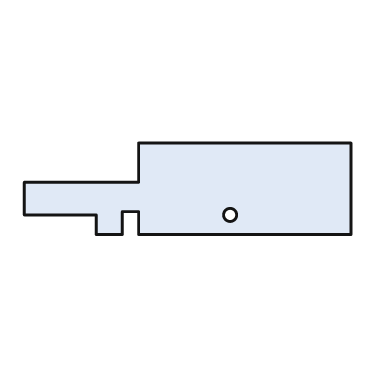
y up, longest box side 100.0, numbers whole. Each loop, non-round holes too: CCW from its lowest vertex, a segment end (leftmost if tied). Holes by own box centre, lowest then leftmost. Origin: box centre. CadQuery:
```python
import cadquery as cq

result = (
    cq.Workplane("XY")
    .moveTo(-28.0, -14.0)
    .lineTo(-20.0, -14.0)
    .lineTo(-20.0, -7.0)
    .lineTo(-15.0, -7.0)
    .lineTo(-15.0, -14.0)
    .lineTo(50.0, -14.0)
    .lineTo(50.0, 14.0)
    .lineTo(-15.0, 14.0)
    .lineTo(-15.0, 2.0)
    .lineTo(-50.0, 2.0)
    .lineTo(-50.0, -8.0)
    .lineTo(-28.0, -8.0)
    .close()
    .moveTo(13.0, -8.0)
    .circle(2.0)
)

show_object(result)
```